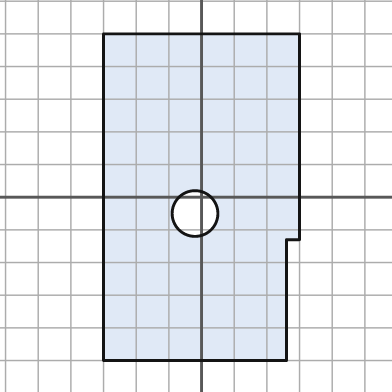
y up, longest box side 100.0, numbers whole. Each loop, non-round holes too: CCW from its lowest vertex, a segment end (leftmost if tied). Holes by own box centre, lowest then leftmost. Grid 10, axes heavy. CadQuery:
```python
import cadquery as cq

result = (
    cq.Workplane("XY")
    .moveTo(-30.0, -50.0)
    .lineTo(26.0, -50.0)
    .lineTo(26.0, -13.0)
    .lineTo(30.0, -13.0)
    .lineTo(30.0, 50.0)
    .lineTo(-30.0, 50.0)
    .close()
    .moveTo(-2.0, -5.0)
    .circle(7.0)
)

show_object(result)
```